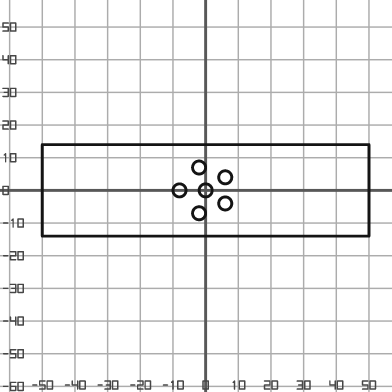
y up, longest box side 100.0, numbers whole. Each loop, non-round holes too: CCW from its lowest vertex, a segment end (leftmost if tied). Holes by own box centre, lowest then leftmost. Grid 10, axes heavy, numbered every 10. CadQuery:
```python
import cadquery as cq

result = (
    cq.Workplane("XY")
    .moveTo(-50.0, -14.0)
    .lineTo(50.0, -14.0)
    .lineTo(50.0, 14.0)
    .lineTo(-50.0, 14.0)
    .close()
    .moveTo(-2.0, -7.0)
    .circle(2.0)
    .moveTo(6.0, -4.0)
    .circle(2.0)
    .moveTo(-8.0, 0.0)
    .circle(2.0)
    .moveTo(0.0, 0.0)
    .circle(2.0)
    .moveTo(6.0, 4.0)
    .circle(2.0)
    .moveTo(-2.0, 7.0)
    .circle(2.0)
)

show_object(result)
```